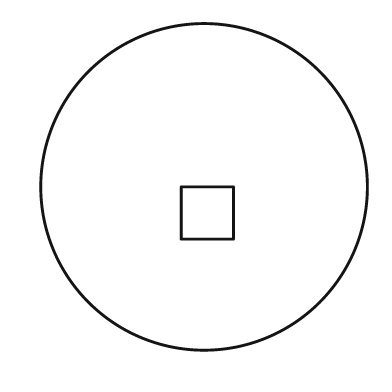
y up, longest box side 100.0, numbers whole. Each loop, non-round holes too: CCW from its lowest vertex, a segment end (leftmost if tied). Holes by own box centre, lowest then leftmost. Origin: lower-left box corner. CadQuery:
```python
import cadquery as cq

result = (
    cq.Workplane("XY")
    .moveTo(50.0, 50.0)
    .circle(50.0)
    .moveTo(43.0, 34.0)
    .lineTo(59.0, 34.0)
    .lineTo(59.0, 50.0)
    .lineTo(43.0, 50.0)
    .close()
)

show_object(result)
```